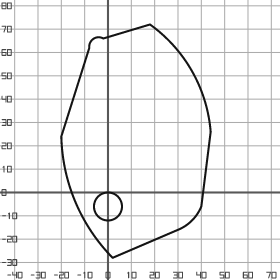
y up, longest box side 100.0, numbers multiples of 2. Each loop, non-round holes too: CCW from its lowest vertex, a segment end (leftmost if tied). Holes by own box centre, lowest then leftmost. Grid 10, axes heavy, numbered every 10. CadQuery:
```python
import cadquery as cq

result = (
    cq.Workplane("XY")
    .moveTo(2.0, -28.0)
    .lineTo(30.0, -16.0)
    .threePointArc((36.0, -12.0), (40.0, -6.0))
    .lineTo(44.0, 26.0)
    .threePointArc((36.0, 52.0), (18.0, 72.0))
    .lineTo(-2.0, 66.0)
    .threePointArc((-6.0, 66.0), (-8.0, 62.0))
    .lineTo(-20.0, 24.0)
    .threePointArc((-14.0, -4.0), (2.0, -28.0))
    .close()
    .moveTo(0.0, -6.0)
    .circle(6.0)
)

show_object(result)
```